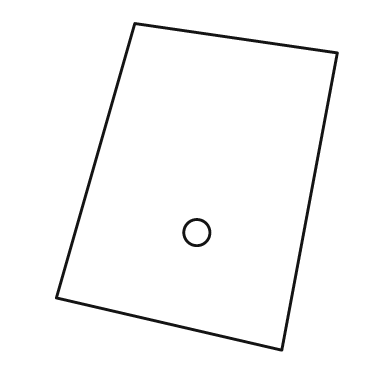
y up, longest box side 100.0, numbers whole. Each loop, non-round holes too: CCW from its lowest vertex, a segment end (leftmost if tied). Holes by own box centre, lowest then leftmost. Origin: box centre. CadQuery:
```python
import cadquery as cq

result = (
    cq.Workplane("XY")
    .moveTo(26.0, -50.0)
    .lineTo(43.0, 41.0)
    .lineTo(-19.0, 50.0)
    .lineTo(-43.0, -34.0)
    .close()
    .moveTo(0.0, -14.0)
    .circle(4.0)
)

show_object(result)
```